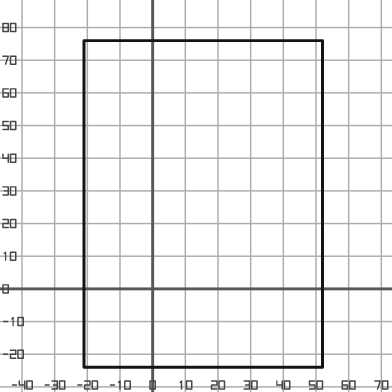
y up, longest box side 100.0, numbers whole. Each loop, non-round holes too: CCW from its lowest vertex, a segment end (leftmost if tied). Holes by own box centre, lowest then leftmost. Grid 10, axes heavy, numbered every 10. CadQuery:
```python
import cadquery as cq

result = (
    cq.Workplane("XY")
    .moveTo(-21.0, -24.0)
    .lineTo(52.0, -24.0)
    .lineTo(52.0, 76.0)
    .lineTo(-21.0, 76.0)
    .close()
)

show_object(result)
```